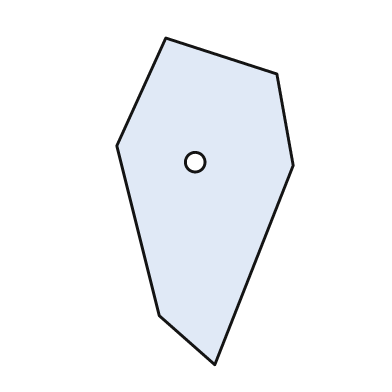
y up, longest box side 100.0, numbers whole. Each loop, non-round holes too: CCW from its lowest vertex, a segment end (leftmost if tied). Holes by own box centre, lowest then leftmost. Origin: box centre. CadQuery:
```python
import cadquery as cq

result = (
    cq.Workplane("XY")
    .moveTo(3.0, -50.0)
    .lineTo(27.0, 11.0)
    .lineTo(22.0, 39.0)
    .lineTo(-12.0, 50.0)
    .lineTo(-27.0, 17.0)
    .lineTo(-14.0, -35.0)
    .close()
    .moveTo(-3.0, 12.0)
    .circle(3.0)
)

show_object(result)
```